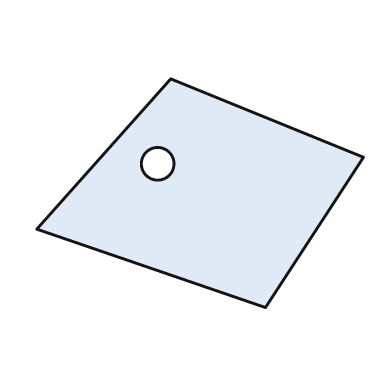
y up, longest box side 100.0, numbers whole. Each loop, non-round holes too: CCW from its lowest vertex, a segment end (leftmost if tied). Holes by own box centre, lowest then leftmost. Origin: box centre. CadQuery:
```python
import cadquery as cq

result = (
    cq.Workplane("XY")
    .moveTo(20.0, -35.0)
    .lineTo(50.0, 11.0)
    .lineTo(-9.0, 35.0)
    .lineTo(-50.0, -11.0)
    .close()
    .moveTo(-13.0, 9.0)
    .circle(5.0)
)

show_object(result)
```